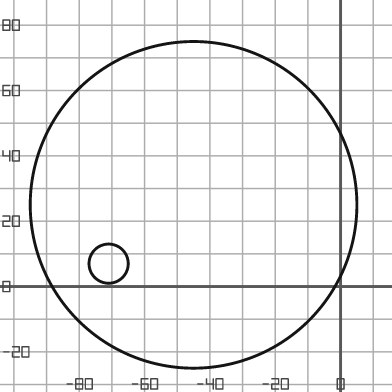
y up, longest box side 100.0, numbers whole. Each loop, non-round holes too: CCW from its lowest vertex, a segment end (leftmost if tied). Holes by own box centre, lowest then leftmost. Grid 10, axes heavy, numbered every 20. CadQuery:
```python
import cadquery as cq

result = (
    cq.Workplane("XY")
    .moveTo(-45.0, 25.0)
    .circle(50.0)
    .moveTo(-71.0, 7.0)
    .circle(6.0)
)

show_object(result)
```